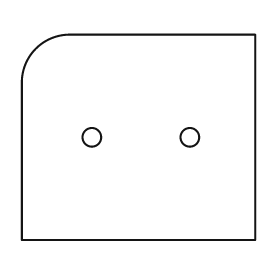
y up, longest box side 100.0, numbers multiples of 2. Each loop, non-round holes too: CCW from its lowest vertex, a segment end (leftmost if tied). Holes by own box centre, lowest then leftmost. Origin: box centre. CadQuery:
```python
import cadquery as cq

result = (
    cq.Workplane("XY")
    .moveTo(-50.0, -44.0)
    .lineTo(50.0, -44.0)
    .lineTo(50.0, 44.0)
    .lineTo(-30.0, 44.0)
    .threePointArc((-44.0, 38.0), (-50.0, 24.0))
    .close()
    .moveTo(-20.0, 0.0)
    .circle(4.0)
    .moveTo(22.0, 0.0)
    .circle(4.0)
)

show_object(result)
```